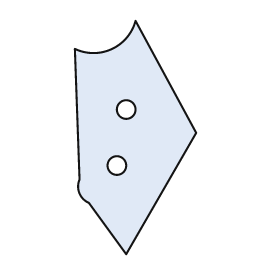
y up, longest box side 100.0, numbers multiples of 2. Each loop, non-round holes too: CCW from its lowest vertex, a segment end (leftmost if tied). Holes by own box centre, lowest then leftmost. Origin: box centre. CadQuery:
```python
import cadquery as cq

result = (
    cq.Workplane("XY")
    .moveTo(-4.0, -50.0)
    .lineTo(26.0, 2.0)
    .lineTo(0.0, 50.0)
    .threePointArc((-10.0, 38.0), (-26.0, 38.0))
    .lineTo(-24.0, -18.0)
    .threePointArc((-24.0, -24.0), (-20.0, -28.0))
    .close()
    .moveTo(-8.0, -12.0)
    .circle(4.0)
    .moveTo(-4.0, 12.0)
    .circle(4.0)
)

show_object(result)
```